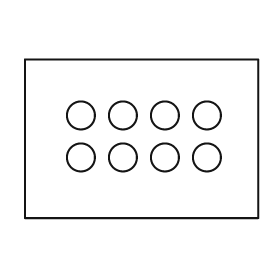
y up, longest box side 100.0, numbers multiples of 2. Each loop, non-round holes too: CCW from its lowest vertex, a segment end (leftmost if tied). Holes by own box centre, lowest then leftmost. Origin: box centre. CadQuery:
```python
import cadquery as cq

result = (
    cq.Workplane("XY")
    .moveTo(-50.0, -34.0)
    .lineTo(50.0, -34.0)
    .lineTo(50.0, 34.0)
    .lineTo(-50.0, 34.0)
    .close()
    .moveTo(-26.0, -8.0)
    .circle(6.0)
    .moveTo(-8.0, -8.0)
    .circle(6.0)
    .moveTo(10.0, -8.0)
    .circle(6.0)
    .moveTo(28.0, -8.0)
    .circle(6.0)
    .moveTo(-26.0, 10.0)
    .circle(6.0)
    .moveTo(-8.0, 10.0)
    .circle(6.0)
    .moveTo(10.0, 10.0)
    .circle(6.0)
    .moveTo(28.0, 10.0)
    .circle(6.0)
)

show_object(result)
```